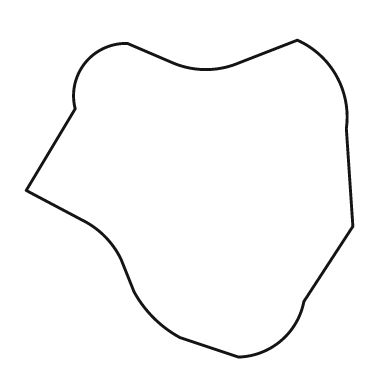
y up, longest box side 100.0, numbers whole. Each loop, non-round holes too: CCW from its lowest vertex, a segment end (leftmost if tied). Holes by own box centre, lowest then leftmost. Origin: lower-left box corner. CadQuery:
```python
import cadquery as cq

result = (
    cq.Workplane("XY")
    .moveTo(65.0, 0.0)
    .threePointArc((78.0, 5.0), (85.0, 17.0))
    .lineTo(100.0, 40.0)
    .lineTo(98.0, 70.0)
    .threePointArc((95.0, 86.0), (83.0, 97.0))
    .lineTo(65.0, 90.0)
    .threePointArc((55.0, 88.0), (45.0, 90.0))
    .lineTo(31.0, 96.0)
    .threePointArc((18.0, 90.0), (15.0, 76.0))
    .lineTo(0.0, 51.0)
    .lineTo(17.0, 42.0)
    .threePointArc((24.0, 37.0), (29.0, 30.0))
    .lineTo(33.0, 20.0)
    .threePointArc((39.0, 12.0), (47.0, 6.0))
    .close()
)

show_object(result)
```